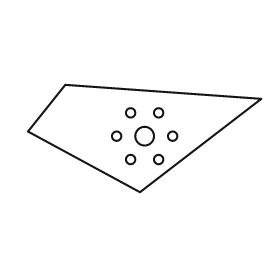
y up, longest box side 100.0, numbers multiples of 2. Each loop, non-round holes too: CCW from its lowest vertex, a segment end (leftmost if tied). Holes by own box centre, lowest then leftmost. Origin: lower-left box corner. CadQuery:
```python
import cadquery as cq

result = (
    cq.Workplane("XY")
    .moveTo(48.0, 0.0)
    .lineTo(100.0, 40.0)
    .lineTo(16.0, 46.0)
    .lineTo(0.0, 26.0)
    .close()
    .moveTo(44.0, 14.0)
    .circle(2.0)
    .moveTo(56.0, 14.0)
    .circle(2.0)
    .moveTo(38.0, 24.0)
    .circle(2.0)
    .moveTo(50.0, 24.0)
    .circle(4.0)
    .moveTo(62.0, 24.0)
    .circle(2.0)
    .moveTo(44.0, 34.0)
    .circle(2.0)
    .moveTo(56.0, 34.0)
    .circle(2.0)
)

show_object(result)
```